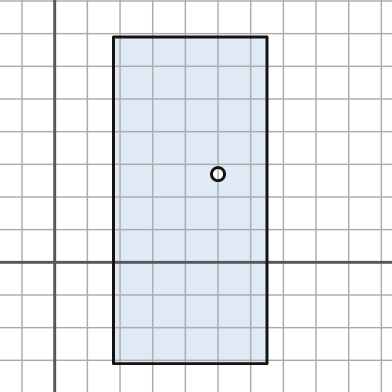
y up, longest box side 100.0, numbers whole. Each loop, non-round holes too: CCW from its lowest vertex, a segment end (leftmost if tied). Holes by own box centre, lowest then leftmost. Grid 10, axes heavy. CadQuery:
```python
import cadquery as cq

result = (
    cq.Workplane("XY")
    .moveTo(18.0, -31.0)
    .lineTo(65.0, -31.0)
    .lineTo(65.0, 69.0)
    .lineTo(18.0, 69.0)
    .close()
    .moveTo(50.0, 27.0)
    .circle(2.0)
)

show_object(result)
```